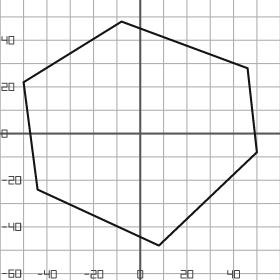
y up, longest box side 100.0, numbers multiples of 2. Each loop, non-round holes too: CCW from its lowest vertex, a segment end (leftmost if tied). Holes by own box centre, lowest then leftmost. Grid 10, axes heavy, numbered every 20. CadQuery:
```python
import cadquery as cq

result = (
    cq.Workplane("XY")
    .moveTo(8.0, -48.0)
    .lineTo(50.0, -8.0)
    .lineTo(46.0, 28.0)
    .lineTo(-8.0, 48.0)
    .lineTo(-50.0, 22.0)
    .lineTo(-44.0, -24.0)
    .close()
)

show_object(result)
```